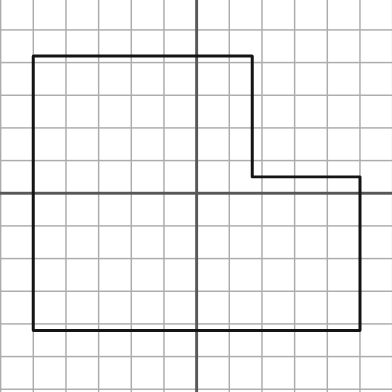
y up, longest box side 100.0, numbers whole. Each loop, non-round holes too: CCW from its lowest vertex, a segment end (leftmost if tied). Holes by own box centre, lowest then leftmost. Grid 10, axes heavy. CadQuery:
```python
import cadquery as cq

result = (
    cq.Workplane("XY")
    .moveTo(-50.0, -42.0)
    .lineTo(50.0, -42.0)
    .lineTo(50.0, 5.0)
    .lineTo(17.0, 5.0)
    .lineTo(17.0, 42.0)
    .lineTo(-50.0, 42.0)
    .close()
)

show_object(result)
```